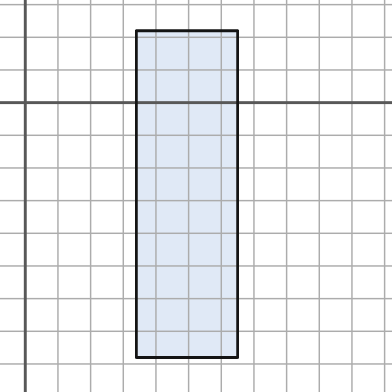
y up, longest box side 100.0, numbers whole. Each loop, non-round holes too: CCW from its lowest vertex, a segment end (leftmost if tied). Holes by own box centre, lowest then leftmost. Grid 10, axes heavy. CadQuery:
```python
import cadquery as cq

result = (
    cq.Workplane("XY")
    .moveTo(34.0, -78.0)
    .lineTo(65.0, -78.0)
    .lineTo(65.0, 22.0)
    .lineTo(34.0, 22.0)
    .close()
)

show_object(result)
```